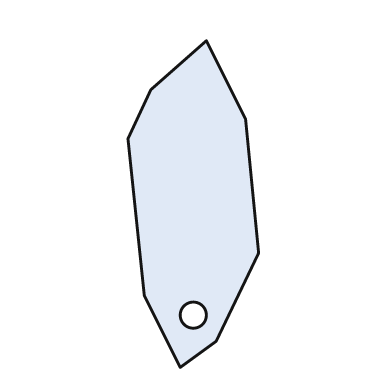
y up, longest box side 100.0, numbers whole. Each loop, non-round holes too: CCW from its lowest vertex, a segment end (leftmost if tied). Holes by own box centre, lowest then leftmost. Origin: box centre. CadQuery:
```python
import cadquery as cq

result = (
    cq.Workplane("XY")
    .moveTo(-4.0, -50.0)
    .lineTo(7.0, -42.0)
    .lineTo(20.0, -15.0)
    .lineTo(16.0, 26.0)
    .lineTo(4.0, 50.0)
    .lineTo(-13.0, 35.0)
    .lineTo(-20.0, 20.0)
    .lineTo(-15.0, -28.0)
    .close()
    .moveTo(0.0, -34.0)
    .circle(4.0)
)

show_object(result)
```